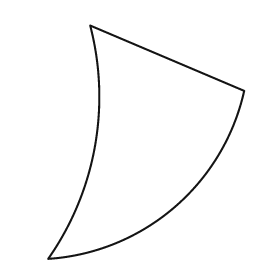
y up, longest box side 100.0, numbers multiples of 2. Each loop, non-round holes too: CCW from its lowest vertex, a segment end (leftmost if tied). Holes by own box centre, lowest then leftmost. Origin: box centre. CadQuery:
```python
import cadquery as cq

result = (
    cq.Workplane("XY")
    .moveTo(-42.0, -50.0)
    .threePointArc((12.0, -28.0), (42.0, 22.0))
    .lineTo(-24.0, 50.0)
    .threePointArc((-22.0, -2.0), (-42.0, -50.0))
    .close()
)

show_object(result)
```